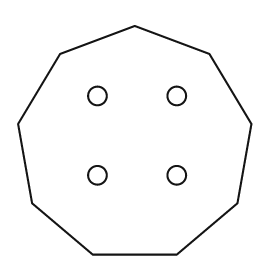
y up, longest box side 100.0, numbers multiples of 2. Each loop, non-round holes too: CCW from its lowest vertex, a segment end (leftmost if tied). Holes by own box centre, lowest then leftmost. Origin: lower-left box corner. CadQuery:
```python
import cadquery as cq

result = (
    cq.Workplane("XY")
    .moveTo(32.0, 0.0)
    .lineTo(68.0, 0.0)
    .lineTo(94.0, 22.0)
    .lineTo(100.0, 56.0)
    .lineTo(82.0, 86.0)
    .lineTo(50.0, 98.0)
    .lineTo(18.0, 86.0)
    .lineTo(0.0, 56.0)
    .lineTo(6.0, 22.0)
    .close()
    .moveTo(34.0, 34.0)
    .circle(4.0)
    .moveTo(68.0, 34.0)
    .circle(4.0)
    .moveTo(34.0, 68.0)
    .circle(4.0)
    .moveTo(68.0, 68.0)
    .circle(4.0)
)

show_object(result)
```